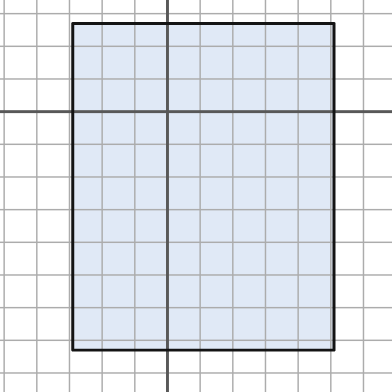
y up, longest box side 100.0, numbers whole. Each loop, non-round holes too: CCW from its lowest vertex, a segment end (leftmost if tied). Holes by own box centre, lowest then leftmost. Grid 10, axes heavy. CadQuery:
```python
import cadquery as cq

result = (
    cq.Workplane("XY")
    .moveTo(-29.0, -73.0)
    .lineTo(51.0, -73.0)
    .lineTo(51.0, 27.0)
    .lineTo(-29.0, 27.0)
    .close()
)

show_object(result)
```